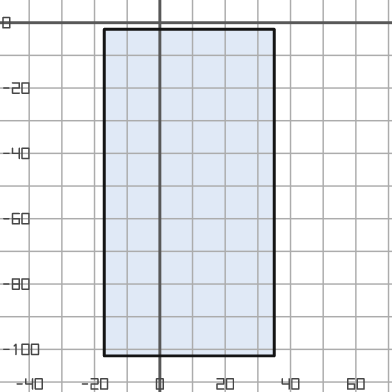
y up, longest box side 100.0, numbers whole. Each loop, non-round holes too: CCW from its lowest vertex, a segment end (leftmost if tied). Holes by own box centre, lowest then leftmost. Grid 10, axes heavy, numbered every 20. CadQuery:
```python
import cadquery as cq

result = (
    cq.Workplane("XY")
    .moveTo(-17.0, -102.0)
    .lineTo(35.0, -102.0)
    .lineTo(35.0, -2.0)
    .lineTo(-17.0, -2.0)
    .close()
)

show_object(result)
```